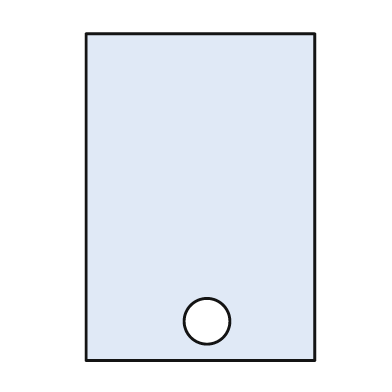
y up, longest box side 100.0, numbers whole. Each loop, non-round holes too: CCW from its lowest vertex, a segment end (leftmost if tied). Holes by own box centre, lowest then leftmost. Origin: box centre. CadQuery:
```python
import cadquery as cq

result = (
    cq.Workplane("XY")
    .moveTo(-35.0, -50.0)
    .lineTo(35.0, -50.0)
    .lineTo(35.0, 50.0)
    .lineTo(-35.0, 50.0)
    .close()
    .moveTo(2.0, -38.0)
    .circle(7.0)
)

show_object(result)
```